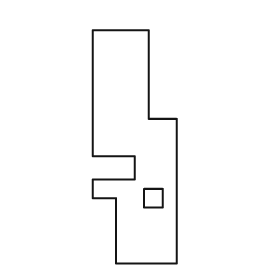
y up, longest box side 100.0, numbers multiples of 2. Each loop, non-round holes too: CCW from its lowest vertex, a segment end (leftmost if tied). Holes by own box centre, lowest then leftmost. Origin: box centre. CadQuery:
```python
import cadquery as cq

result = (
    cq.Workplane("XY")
    .moveTo(-8.0, -50.0)
    .lineTo(18.0, -50.0)
    .lineTo(18.0, 12.0)
    .lineTo(6.0, 12.0)
    .lineTo(6.0, 50.0)
    .lineTo(-18.0, 50.0)
    .lineTo(-18.0, -4.0)
    .lineTo(0.0, -4.0)
    .lineTo(0.0, -14.0)
    .lineTo(-18.0, -14.0)
    .lineTo(-18.0, -22.0)
    .lineTo(-8.0, -22.0)
    .close()
    .moveTo(4.0, -26.0)
    .lineTo(12.0, -26.0)
    .lineTo(12.0, -18.0)
    .lineTo(4.0, -18.0)
    .close()
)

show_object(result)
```